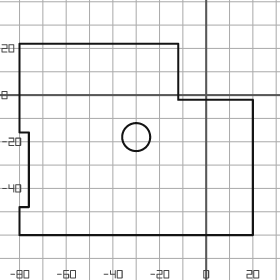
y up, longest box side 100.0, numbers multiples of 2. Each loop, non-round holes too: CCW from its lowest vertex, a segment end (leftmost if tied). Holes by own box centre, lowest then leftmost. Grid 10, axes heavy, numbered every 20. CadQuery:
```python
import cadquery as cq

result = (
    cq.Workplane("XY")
    .moveTo(-80.0, -60.0)
    .lineTo(20.0, -60.0)
    .lineTo(20.0, -2.0)
    .lineTo(-12.0, -2.0)
    .lineTo(-12.0, 22.0)
    .lineTo(-80.0, 22.0)
    .lineTo(-80.0, -16.0)
    .lineTo(-76.0, -16.0)
    .lineTo(-76.0, -48.0)
    .lineTo(-80.0, -48.0)
    .close()
    .moveTo(-30.0, -18.0)
    .circle(6.0)
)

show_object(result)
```